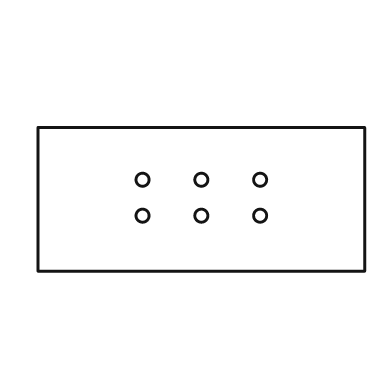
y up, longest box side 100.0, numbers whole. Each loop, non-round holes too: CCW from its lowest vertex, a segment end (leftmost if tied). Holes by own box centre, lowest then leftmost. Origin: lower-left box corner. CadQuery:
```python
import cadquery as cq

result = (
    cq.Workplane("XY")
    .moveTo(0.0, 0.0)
    .lineTo(100.0, 0.0)
    .lineTo(100.0, 44.0)
    .lineTo(0.0, 44.0)
    .close()
    .moveTo(32.0, 17.0)
    .circle(2.0)
    .moveTo(50.0, 17.0)
    .circle(2.0)
    .moveTo(68.0, 17.0)
    .circle(2.0)
    .moveTo(32.0, 28.0)
    .circle(2.0)
    .moveTo(50.0, 28.0)
    .circle(2.0)
    .moveTo(68.0, 28.0)
    .circle(2.0)
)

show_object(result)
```